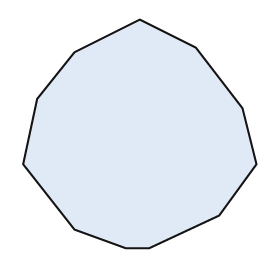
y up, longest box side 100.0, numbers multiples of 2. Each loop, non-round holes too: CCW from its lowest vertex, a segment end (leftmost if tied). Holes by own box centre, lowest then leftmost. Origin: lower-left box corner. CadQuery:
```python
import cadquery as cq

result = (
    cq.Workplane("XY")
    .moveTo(44.0, 0.0)
    .lineTo(54.0, 0.0)
    .lineTo(84.0, 14.0)
    .lineTo(100.0, 36.0)
    .lineTo(94.0, 60.0)
    .lineTo(74.0, 86.0)
    .lineTo(50.0, 98.0)
    .lineTo(22.0, 84.0)
    .lineTo(6.0, 64.0)
    .lineTo(0.0, 36.0)
    .lineTo(22.0, 8.0)
    .close()
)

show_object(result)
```